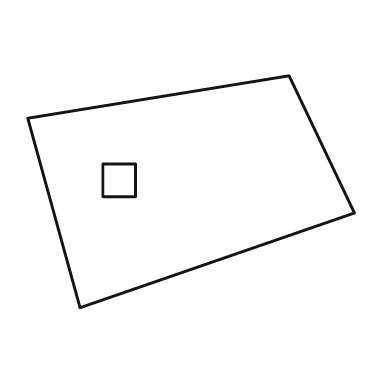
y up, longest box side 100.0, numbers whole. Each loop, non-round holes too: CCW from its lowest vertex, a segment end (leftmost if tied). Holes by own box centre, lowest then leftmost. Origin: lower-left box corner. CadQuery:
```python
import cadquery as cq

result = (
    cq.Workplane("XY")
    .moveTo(16.0, 0.0)
    .lineTo(100.0, 29.0)
    .lineTo(80.0, 71.0)
    .lineTo(0.0, 58.0)
    .close()
    .moveTo(23.0, 34.0)
    .lineTo(33.0, 34.0)
    .lineTo(33.0, 44.0)
    .lineTo(23.0, 44.0)
    .close()
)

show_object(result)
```